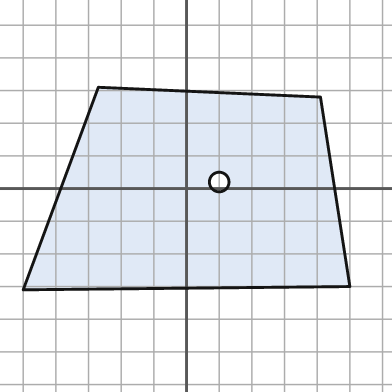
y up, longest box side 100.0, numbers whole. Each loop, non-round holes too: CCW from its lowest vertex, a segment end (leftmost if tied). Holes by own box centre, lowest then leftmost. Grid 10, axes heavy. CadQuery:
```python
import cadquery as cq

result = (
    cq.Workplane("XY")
    .moveTo(-50.0, -31.0)
    .lineTo(50.0, -30.0)
    .lineTo(41.0, 28.0)
    .lineTo(-27.0, 31.0)
    .close()
    .moveTo(10.0, 2.0)
    .circle(3.0)
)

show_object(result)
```